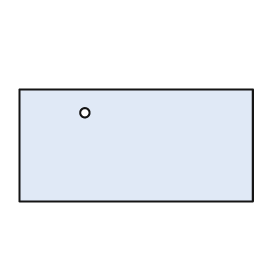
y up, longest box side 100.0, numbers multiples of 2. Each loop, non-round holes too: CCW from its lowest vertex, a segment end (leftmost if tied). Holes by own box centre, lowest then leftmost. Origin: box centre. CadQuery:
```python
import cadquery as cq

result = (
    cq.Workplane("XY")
    .moveTo(-50.0, -24.0)
    .lineTo(50.0, -24.0)
    .lineTo(50.0, 24.0)
    .lineTo(-50.0, 24.0)
    .close()
    .moveTo(-22.0, 14.0)
    .circle(2.0)
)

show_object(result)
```